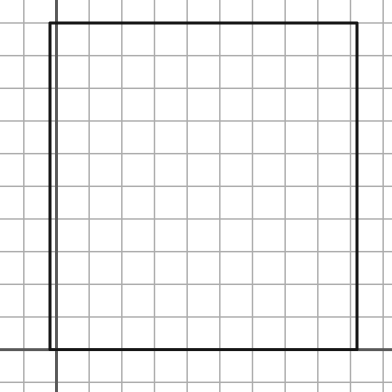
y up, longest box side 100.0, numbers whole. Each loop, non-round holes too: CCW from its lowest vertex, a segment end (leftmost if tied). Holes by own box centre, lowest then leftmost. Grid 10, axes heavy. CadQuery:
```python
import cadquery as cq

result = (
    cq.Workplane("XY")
    .moveTo(-2.0, 0.0)
    .lineTo(92.0, 0.0)
    .lineTo(92.0, 100.0)
    .lineTo(-2.0, 100.0)
    .close()
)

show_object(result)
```